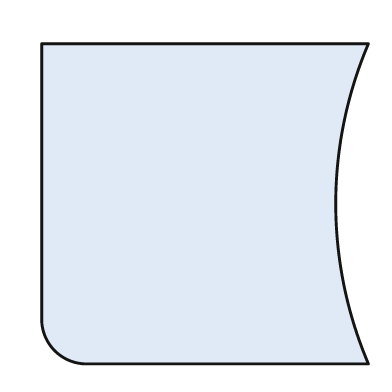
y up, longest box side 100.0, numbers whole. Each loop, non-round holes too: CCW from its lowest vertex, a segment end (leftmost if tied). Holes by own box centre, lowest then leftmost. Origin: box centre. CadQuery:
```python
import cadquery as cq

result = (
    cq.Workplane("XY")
    .moveTo(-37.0, -49.0)
    .lineTo(50.0, -49.0)
    .threePointArc((40.0, 0.0), (50.0, 49.0))
    .lineTo(-50.0, 49.0)
    .lineTo(-50.0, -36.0)
    .threePointArc((-46.0, -45.0), (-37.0, -49.0))
    .close()
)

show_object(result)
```